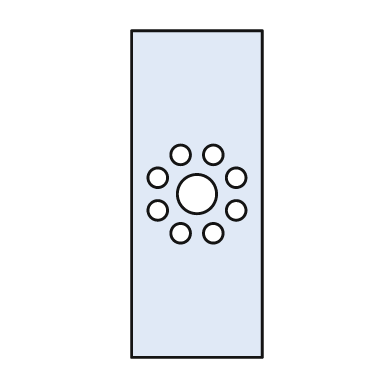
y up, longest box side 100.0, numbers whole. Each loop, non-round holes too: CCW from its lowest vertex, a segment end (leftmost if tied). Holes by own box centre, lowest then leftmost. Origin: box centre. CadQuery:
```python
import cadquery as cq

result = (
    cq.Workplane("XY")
    .moveTo(-20.0, -50.0)
    .lineTo(20.0, -50.0)
    .lineTo(20.0, 50.0)
    .lineTo(-20.0, 50.0)
    .close()
    .moveTo(-5.0, -12.0)
    .circle(3.0)
    .moveTo(5.0, -12.0)
    .circle(3.0)
    .moveTo(-12.0, -5.0)
    .circle(3.0)
    .moveTo(12.0, -5.0)
    .circle(3.0)
    .moveTo(0.0, 0.0)
    .circle(6.0)
    .moveTo(-12.0, 5.0)
    .circle(3.0)
    .moveTo(12.0, 5.0)
    .circle(3.0)
    .moveTo(-5.0, 12.0)
    .circle(3.0)
    .moveTo(5.0, 12.0)
    .circle(3.0)
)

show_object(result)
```